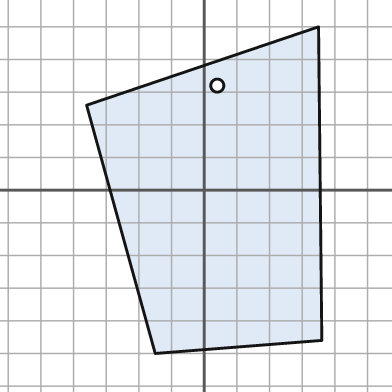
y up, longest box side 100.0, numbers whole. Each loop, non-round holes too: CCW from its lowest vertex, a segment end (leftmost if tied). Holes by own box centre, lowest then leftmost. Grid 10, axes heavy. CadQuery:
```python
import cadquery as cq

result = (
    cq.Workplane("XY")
    .moveTo(-15.0, -50.0)
    .lineTo(36.0, -46.0)
    .lineTo(35.0, 50.0)
    .lineTo(-36.0, 26.0)
    .close()
    .moveTo(4.0, 32.0)
    .circle(2.0)
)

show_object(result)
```